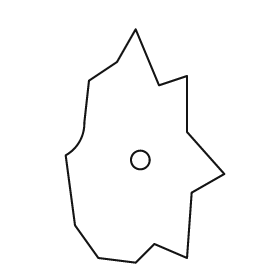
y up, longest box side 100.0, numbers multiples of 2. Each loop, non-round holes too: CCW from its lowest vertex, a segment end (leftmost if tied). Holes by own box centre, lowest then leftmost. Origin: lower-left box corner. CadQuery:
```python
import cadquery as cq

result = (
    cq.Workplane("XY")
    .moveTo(30.0, 0.0)
    .lineTo(38.0, 8.0)
    .lineTo(52.0, 2.0)
    .lineTo(54.0, 30.0)
    .lineTo(68.0, 38.0)
    .lineTo(52.0, 56.0)
    .lineTo(52.0, 80.0)
    .lineTo(40.0, 76.0)
    .lineTo(30.0, 100.0)
    .lineTo(22.0, 86.0)
    .lineTo(10.0, 78.0)
    .lineTo(8.0, 60.0)
    .threePointArc((6.0, 52.0), (0.0, 46.0))
    .lineTo(4.0, 16.0)
    .lineTo(14.0, 2.0)
    .close()
    .moveTo(32.0, 44.0)
    .circle(4.0)
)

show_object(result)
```